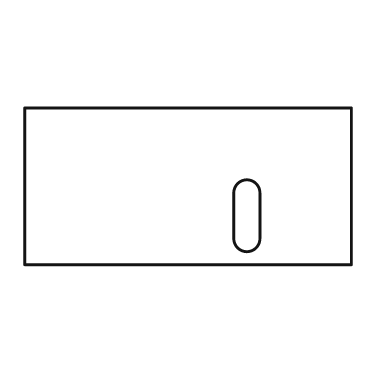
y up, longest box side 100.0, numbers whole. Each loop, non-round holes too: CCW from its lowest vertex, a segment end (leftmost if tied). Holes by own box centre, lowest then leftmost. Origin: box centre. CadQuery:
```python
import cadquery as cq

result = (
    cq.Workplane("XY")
    .moveTo(-50.0, -24.0)
    .lineTo(50.0, -24.0)
    .lineTo(50.0, 24.0)
    .lineTo(-50.0, 24.0)
    .close()
    .moveTo(14.0, -16.0)
    .threePointArc((18.0, -20.0), (22.0, -16.0))
    .lineTo(22.0, -2.0)
    .threePointArc((18.0, 2.0), (14.0, -2.0))
    .close()
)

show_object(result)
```